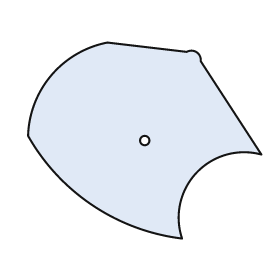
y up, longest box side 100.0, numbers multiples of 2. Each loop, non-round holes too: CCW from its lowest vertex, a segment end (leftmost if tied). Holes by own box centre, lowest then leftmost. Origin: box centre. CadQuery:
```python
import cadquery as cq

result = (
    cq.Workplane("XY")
    .moveTo(16.0, -42.0)
    .threePointArc((22.0, -14.0), (50.0, -6.0))
    .lineTo(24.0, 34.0)
    .threePointArc((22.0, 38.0), (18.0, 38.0))
    .lineTo(-16.0, 42.0)
    .threePointArc((-40.0, 28.0), (-50.0, 2.0))
    .threePointArc((-22.0, -28.0), (16.0, -42.0))
    .close()
    .moveTo(0.0, 0.0)
    .circle(2.0)
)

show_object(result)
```